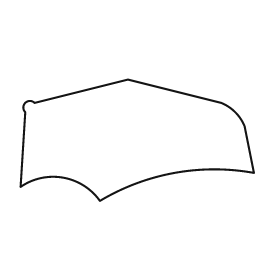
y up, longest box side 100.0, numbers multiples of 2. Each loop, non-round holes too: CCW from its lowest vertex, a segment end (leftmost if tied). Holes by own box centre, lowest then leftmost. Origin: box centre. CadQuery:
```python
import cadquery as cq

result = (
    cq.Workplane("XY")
    .moveTo(-16.0, -26.0)
    .threePointArc((16.0, -14.0), (50.0, -14.0))
    .lineTo(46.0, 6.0)
    .threePointArc((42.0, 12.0), (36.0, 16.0))
    .lineTo(-4.0, 26.0)
    .lineTo(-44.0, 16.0)
    .threePointArc((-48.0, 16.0), (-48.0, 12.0))
    .lineTo(-50.0, -20.0)
    .threePointArc((-32.0, -16.0), (-16.0, -26.0))
    .close()
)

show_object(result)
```